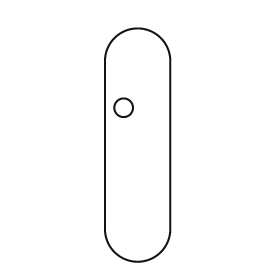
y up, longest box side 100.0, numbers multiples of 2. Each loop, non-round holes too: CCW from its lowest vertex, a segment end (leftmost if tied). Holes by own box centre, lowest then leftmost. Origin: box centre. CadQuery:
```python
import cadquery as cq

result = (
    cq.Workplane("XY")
    .moveTo(-14.0, -36.0)
    .threePointArc((0.0, -50.0), (14.0, -36.0))
    .lineTo(14.0, 36.0)
    .threePointArc((0.0, 50.0), (-14.0, 36.0))
    .close()
    .moveTo(-6.0, 16.0)
    .circle(4.0)
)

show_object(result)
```